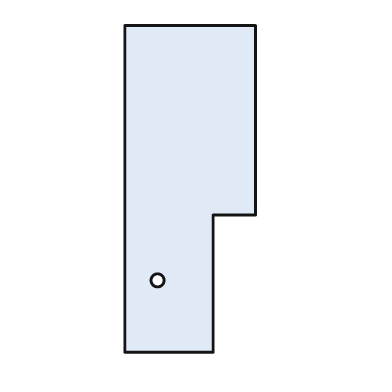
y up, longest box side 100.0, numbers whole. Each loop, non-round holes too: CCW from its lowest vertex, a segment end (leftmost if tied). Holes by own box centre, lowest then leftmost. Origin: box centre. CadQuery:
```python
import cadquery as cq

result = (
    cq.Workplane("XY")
    .moveTo(-20.0, -50.0)
    .lineTo(7.0, -50.0)
    .lineTo(7.0, -8.0)
    .lineTo(20.0, -8.0)
    .lineTo(20.0, 50.0)
    .lineTo(-20.0, 50.0)
    .close()
    .moveTo(-10.0, -28.0)
    .circle(2.0)
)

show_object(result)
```